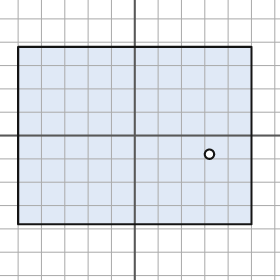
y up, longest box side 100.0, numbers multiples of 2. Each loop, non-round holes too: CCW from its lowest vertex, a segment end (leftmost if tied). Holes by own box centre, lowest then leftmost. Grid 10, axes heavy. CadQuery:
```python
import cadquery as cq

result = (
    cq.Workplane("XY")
    .moveTo(-50.0, -38.0)
    .lineTo(50.0, -38.0)
    .lineTo(50.0, 38.0)
    .lineTo(-50.0, 38.0)
    .close()
    .moveTo(32.0, -8.0)
    .circle(2.0)
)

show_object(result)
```